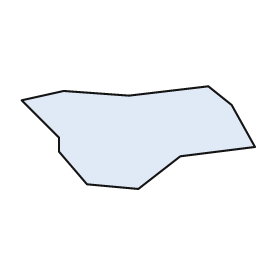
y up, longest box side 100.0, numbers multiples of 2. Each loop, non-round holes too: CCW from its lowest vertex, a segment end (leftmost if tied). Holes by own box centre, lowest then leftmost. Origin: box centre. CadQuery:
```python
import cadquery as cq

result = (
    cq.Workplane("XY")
    .moveTo(0.0, -22.0)
    .lineTo(18.0, -8.0)
    .lineTo(50.0, -4.0)
    .lineTo(40.0, 14.0)
    .lineTo(30.0, 22.0)
    .lineTo(-4.0, 18.0)
    .lineTo(-32.0, 20.0)
    .lineTo(-50.0, 16.0)
    .lineTo(-34.0, 0.0)
    .lineTo(-34.0, -6.0)
    .lineTo(-22.0, -20.0)
    .close()
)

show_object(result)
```